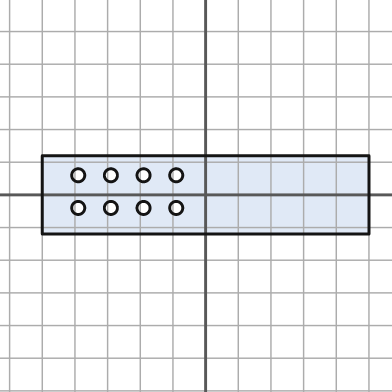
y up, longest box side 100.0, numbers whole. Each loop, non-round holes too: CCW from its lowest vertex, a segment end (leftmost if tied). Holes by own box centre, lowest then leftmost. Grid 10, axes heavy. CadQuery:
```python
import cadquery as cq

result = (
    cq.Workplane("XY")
    .moveTo(-50.0, -12.0)
    .lineTo(50.0, -12.0)
    .lineTo(50.0, 12.0)
    .lineTo(-50.0, 12.0)
    .close()
    .moveTo(-39.0, -4.0)
    .circle(2.0)
    .moveTo(-29.0, -4.0)
    .circle(2.0)
    .moveTo(-19.0, -4.0)
    .circle(2.0)
    .moveTo(-9.0, -4.0)
    .circle(2.0)
    .moveTo(-39.0, 6.0)
    .circle(2.0)
    .moveTo(-29.0, 6.0)
    .circle(2.0)
    .moveTo(-19.0, 6.0)
    .circle(2.0)
    .moveTo(-9.0, 6.0)
    .circle(2.0)
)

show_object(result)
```